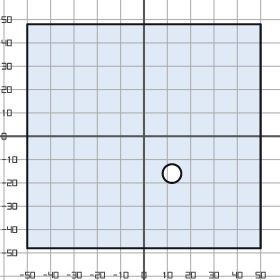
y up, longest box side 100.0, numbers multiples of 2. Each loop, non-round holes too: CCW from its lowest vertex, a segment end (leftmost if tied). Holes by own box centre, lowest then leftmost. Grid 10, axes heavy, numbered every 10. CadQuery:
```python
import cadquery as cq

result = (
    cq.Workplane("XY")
    .moveTo(-50.0, -48.0)
    .lineTo(50.0, -48.0)
    .lineTo(50.0, 48.0)
    .lineTo(-50.0, 48.0)
    .close()
    .moveTo(12.0, -16.0)
    .circle(4.0)
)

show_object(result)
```